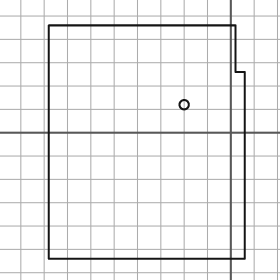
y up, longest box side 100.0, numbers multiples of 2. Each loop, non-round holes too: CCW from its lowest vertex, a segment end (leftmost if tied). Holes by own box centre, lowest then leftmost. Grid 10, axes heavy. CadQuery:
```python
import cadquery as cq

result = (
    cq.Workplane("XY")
    .moveTo(-78.0, -54.0)
    .lineTo(6.0, -54.0)
    .lineTo(6.0, 26.0)
    .lineTo(2.0, 26.0)
    .lineTo(2.0, 46.0)
    .lineTo(-78.0, 46.0)
    .close()
    .moveTo(-20.0, 12.0)
    .circle(2.0)
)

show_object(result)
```